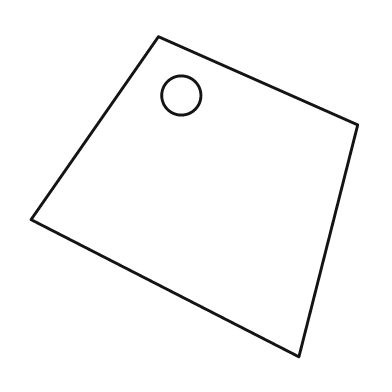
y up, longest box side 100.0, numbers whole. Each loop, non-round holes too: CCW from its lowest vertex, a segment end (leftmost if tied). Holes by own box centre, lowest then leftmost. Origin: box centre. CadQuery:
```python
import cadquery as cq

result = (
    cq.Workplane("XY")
    .moveTo(32.0, -49.0)
    .lineTo(50.0, 22.0)
    .lineTo(-11.0, 49.0)
    .lineTo(-50.0, -7.0)
    .close()
    .moveTo(-4.0, 31.0)
    .circle(6.0)
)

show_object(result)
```